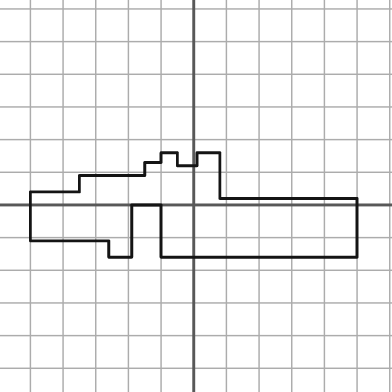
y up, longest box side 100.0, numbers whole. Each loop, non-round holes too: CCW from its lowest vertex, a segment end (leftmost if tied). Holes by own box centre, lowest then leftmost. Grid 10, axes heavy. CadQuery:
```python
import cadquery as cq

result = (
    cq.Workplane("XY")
    .moveTo(-26.0, -16.0)
    .lineTo(-19.0, -16.0)
    .lineTo(-19.0, 0.0)
    .lineTo(-10.0, 0.0)
    .lineTo(-10.0, -16.0)
    .lineTo(50.0, -16.0)
    .lineTo(50.0, 2.0)
    .lineTo(8.0, 2.0)
    .lineTo(8.0, 16.0)
    .lineTo(1.0, 16.0)
    .lineTo(1.0, 12.0)
    .lineTo(-5.0, 12.0)
    .lineTo(-5.0, 16.0)
    .lineTo(-10.0, 16.0)
    .lineTo(-10.0, 13.0)
    .lineTo(-15.0, 13.0)
    .lineTo(-15.0, 9.0)
    .lineTo(-35.0, 9.0)
    .lineTo(-35.0, 4.0)
    .lineTo(-50.0, 4.0)
    .lineTo(-50.0, -11.0)
    .lineTo(-26.0, -11.0)
    .close()
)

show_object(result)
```